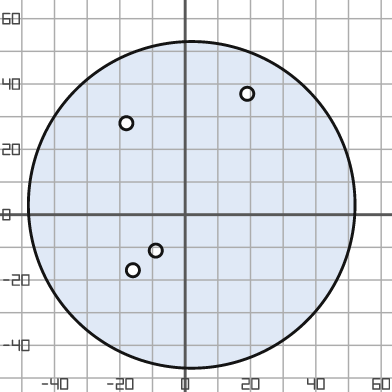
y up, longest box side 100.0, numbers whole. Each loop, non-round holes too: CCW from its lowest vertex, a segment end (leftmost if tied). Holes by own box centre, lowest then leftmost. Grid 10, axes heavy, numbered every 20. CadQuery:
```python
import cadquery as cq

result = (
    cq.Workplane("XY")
    .moveTo(2.0, 3.0)
    .circle(50.0)
    .moveTo(-16.0, -17.0)
    .circle(2.0)
    .moveTo(-9.0, -11.0)
    .circle(2.0)
    .moveTo(-18.0, 28.0)
    .circle(2.0)
    .moveTo(19.0, 37.0)
    .circle(2.0)
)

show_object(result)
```